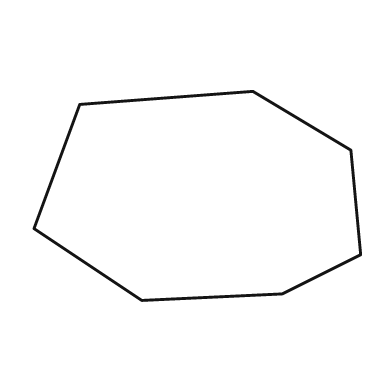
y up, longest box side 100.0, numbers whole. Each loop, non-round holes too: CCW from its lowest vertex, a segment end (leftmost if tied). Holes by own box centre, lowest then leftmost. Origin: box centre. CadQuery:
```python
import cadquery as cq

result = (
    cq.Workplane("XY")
    .moveTo(-17.0, -32.0)
    .lineTo(26.0, -30.0)
    .lineTo(50.0, -18.0)
    .lineTo(47.0, 14.0)
    .lineTo(17.0, 32.0)
    .lineTo(-36.0, 28.0)
    .lineTo(-50.0, -10.0)
    .close()
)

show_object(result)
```